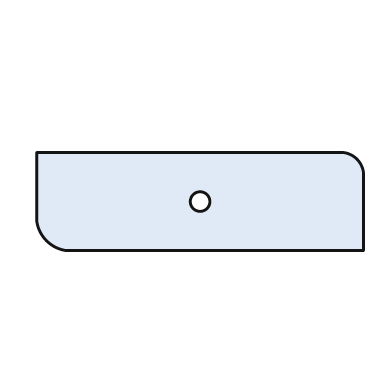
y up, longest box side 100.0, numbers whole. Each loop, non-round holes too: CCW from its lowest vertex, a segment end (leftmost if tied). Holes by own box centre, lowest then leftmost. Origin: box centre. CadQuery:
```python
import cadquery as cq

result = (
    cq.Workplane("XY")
    .moveTo(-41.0, -15.0)
    .lineTo(50.0, -15.0)
    .lineTo(50.0, 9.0)
    .threePointArc((48.0, 13.0), (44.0, 15.0))
    .lineTo(-50.0, 15.0)
    .lineTo(-50.0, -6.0)
    .threePointArc((-47.0, -12.0), (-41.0, -15.0))
    .close()
    .moveTo(0.0, 0.0)
    .circle(3.0)
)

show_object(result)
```